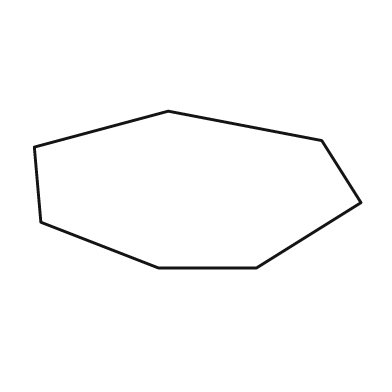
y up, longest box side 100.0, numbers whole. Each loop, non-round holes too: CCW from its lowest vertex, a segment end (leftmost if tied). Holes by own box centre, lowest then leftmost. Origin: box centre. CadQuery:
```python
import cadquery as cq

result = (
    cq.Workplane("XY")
    .moveTo(-12.0, -24.0)
    .lineTo(18.0, -24.0)
    .lineTo(50.0, -4.0)
    .lineTo(38.0, 15.0)
    .lineTo(-9.0, 24.0)
    .lineTo(-50.0, 13.0)
    .lineTo(-48.0, -10.0)
    .close()
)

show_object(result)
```